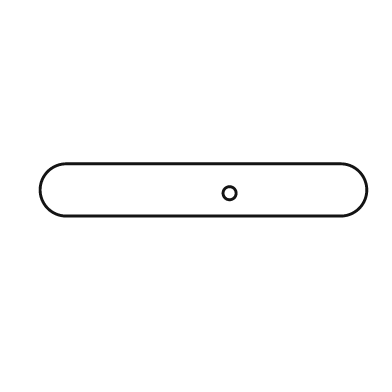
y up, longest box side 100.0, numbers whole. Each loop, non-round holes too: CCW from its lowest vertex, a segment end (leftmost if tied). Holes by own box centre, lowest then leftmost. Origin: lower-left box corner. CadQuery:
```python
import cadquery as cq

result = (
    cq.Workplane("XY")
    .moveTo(8.0, 0.0)
    .lineTo(92.0, 0.0)
    .threePointArc((100.0, 8.0), (92.0, 16.0))
    .lineTo(8.0, 16.0)
    .threePointArc((0.0, 8.0), (8.0, 0.0))
    .close()
    .moveTo(58.0, 7.0)
    .circle(2.0)
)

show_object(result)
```